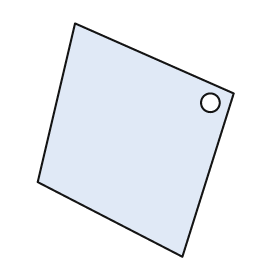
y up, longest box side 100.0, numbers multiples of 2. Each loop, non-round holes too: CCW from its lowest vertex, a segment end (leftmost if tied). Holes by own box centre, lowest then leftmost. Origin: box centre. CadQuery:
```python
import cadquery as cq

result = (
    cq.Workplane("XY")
    .moveTo(20.0, -50.0)
    .lineTo(42.0, 20.0)
    .lineTo(-26.0, 50.0)
    .lineTo(-42.0, -18.0)
    .close()
    .moveTo(32.0, 16.0)
    .circle(4.0)
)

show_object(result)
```